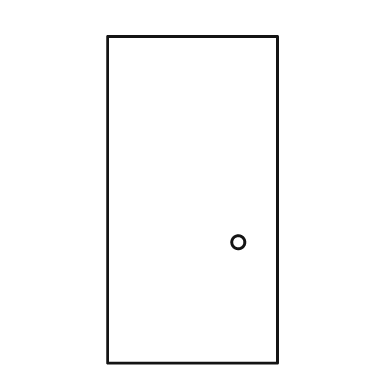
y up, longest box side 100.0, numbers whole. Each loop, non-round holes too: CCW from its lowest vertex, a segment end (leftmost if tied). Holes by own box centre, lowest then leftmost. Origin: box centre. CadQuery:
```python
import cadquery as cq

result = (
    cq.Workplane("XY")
    .moveTo(-26.0, -50.0)
    .lineTo(26.0, -50.0)
    .lineTo(26.0, 50.0)
    .lineTo(-26.0, 50.0)
    .close()
    .moveTo(14.0, -13.0)
    .circle(2.0)
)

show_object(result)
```